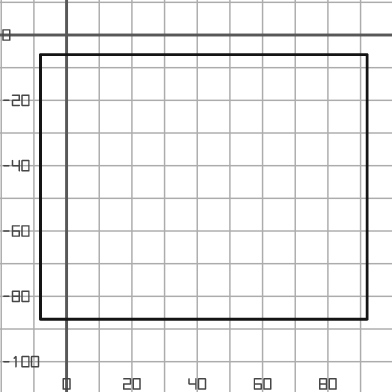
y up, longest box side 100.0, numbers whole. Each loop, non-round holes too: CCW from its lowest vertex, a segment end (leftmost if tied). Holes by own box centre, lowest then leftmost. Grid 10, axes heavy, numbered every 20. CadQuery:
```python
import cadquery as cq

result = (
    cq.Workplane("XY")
    .moveTo(-8.0, -87.0)
    .lineTo(92.0, -87.0)
    .lineTo(92.0, -6.0)
    .lineTo(-8.0, -6.0)
    .close()
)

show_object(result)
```